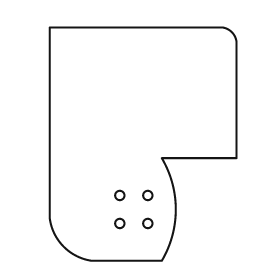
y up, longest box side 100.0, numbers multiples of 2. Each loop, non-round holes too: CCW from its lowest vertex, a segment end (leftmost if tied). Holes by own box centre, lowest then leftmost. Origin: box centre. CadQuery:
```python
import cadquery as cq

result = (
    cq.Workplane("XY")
    .moveTo(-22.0, -50.0)
    .lineTo(8.0, -50.0)
    .threePointArc((14.0, -28.0), (8.0, -6.0))
    .lineTo(40.0, -6.0)
    .lineTo(40.0, 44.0)
    .threePointArc((38.0, 48.0), (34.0, 50.0))
    .lineTo(-40.0, 50.0)
    .lineTo(-40.0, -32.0)
    .threePointArc((-34.0, -44.0), (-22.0, -50.0))
    .close()
    .moveTo(-10.0, -34.0)
    .circle(2.0)
    .moveTo(2.0, -34.0)
    .circle(2.0)
    .moveTo(-10.0, -22.0)
    .circle(2.0)
    .moveTo(2.0, -22.0)
    .circle(2.0)
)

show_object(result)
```